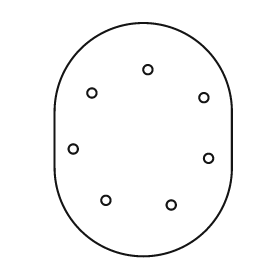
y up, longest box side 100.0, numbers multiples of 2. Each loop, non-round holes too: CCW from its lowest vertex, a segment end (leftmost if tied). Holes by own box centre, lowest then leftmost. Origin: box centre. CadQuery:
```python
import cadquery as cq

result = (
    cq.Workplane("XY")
    .moveTo(-38.0, -12.0)
    .threePointArc((0.0, -50.0), (38.0, -12.0))
    .lineTo(38.0, 12.0)
    .threePointArc((0.0, 50.0), (-38.0, 12.0))
    .close()
    .moveTo(12.0, -28.0)
    .circle(2.0)
    .moveTo(-16.0, -26.0)
    .circle(2.0)
    .moveTo(28.0, -8.0)
    .circle(2.0)
    .moveTo(-30.0, -4.0)
    .circle(2.0)
    .moveTo(26.0, 18.0)
    .circle(2.0)
    .moveTo(-22.0, 20.0)
    .circle(2.0)
    .moveTo(2.0, 30.0)
    .circle(2.0)
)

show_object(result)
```